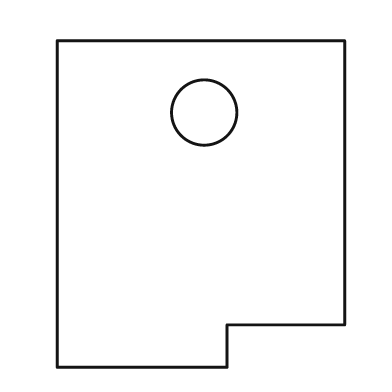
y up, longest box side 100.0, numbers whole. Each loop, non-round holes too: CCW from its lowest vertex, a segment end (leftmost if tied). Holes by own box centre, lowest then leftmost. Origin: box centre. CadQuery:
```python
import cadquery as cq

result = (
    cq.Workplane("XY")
    .moveTo(-44.0, -50.0)
    .lineTo(8.0, -50.0)
    .lineTo(8.0, -37.0)
    .lineTo(44.0, -37.0)
    .lineTo(44.0, 50.0)
    .lineTo(-44.0, 50.0)
    .close()
    .moveTo(1.0, 28.0)
    .circle(10.0)
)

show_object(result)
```